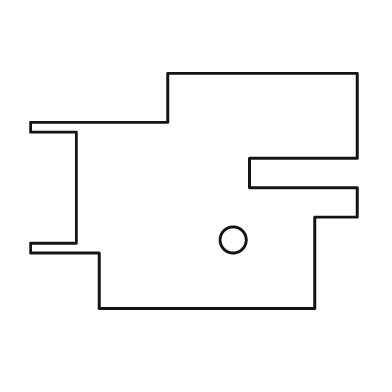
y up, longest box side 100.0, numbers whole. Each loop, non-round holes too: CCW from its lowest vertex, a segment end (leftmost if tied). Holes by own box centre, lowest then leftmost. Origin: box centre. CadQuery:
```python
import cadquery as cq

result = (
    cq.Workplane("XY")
    .moveTo(-29.0, -36.0)
    .lineTo(37.0, -36.0)
    .lineTo(37.0, -8.0)
    .lineTo(50.0, -8.0)
    .lineTo(50.0, 1.0)
    .lineTo(17.0, 1.0)
    .lineTo(17.0, 10.0)
    .lineTo(50.0, 10.0)
    .lineTo(50.0, 36.0)
    .lineTo(-8.0, 36.0)
    .lineTo(-8.0, 21.0)
    .lineTo(-50.0, 21.0)
    .lineTo(-50.0, 18.0)
    .lineTo(-36.0, 18.0)
    .lineTo(-36.0, -16.0)
    .lineTo(-50.0, -16.0)
    .lineTo(-50.0, -19.0)
    .lineTo(-29.0, -19.0)
    .close()
    .moveTo(12.0, -15.0)
    .circle(4.0)
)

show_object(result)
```